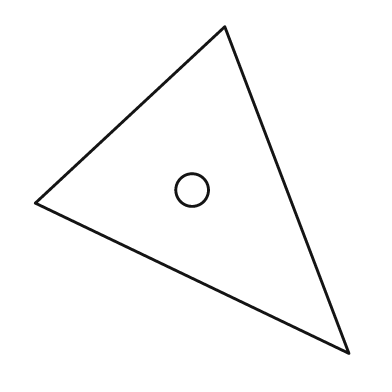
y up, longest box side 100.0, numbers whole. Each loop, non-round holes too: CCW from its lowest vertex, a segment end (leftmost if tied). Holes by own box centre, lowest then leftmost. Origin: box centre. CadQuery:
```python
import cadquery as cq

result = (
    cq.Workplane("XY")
    .moveTo(48.0, -50.0)
    .lineTo(10.0, 50.0)
    .lineTo(-48.0, -4.0)
    .close()
    .moveTo(0.0, 0.0)
    .circle(5.0)
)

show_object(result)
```